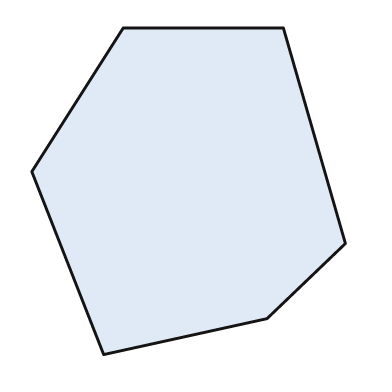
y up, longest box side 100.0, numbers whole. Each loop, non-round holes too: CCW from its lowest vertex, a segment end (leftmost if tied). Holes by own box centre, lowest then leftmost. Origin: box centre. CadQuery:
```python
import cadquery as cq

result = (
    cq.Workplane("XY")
    .moveTo(-26.0, -50.0)
    .lineTo(24.0, -39.0)
    .lineTo(48.0, -16.0)
    .lineTo(29.0, 50.0)
    .lineTo(-20.0, 50.0)
    .lineTo(-48.0, 6.0)
    .close()
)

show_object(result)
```